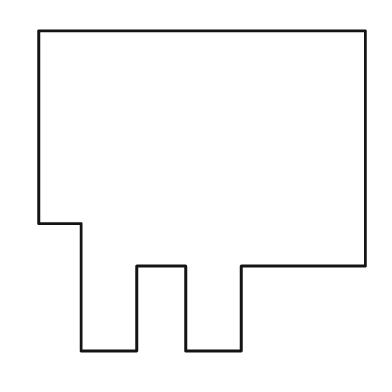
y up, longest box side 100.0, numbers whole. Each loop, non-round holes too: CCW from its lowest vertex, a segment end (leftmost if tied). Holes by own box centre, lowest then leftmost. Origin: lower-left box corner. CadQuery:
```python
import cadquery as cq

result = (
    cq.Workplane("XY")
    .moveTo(13.0, 0.0)
    .lineTo(30.0, 0.0)
    .lineTo(30.0, 26.0)
    .lineTo(45.0, 26.0)
    .lineTo(45.0, 0.0)
    .lineTo(62.0, 0.0)
    .lineTo(62.0, 26.0)
    .lineTo(100.0, 26.0)
    .lineTo(100.0, 98.0)
    .lineTo(0.0, 98.0)
    .lineTo(0.0, 39.0)
    .lineTo(13.0, 39.0)
    .close()
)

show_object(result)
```